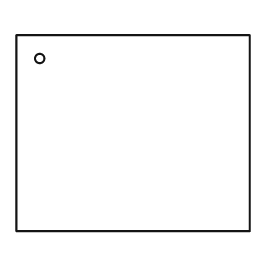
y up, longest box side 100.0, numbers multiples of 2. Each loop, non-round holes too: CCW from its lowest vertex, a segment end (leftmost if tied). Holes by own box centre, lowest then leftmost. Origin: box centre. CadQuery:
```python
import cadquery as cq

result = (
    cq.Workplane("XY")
    .moveTo(-50.0, -42.0)
    .lineTo(50.0, -42.0)
    .lineTo(50.0, 42.0)
    .lineTo(-50.0, 42.0)
    .close()
    .moveTo(-40.0, 32.0)
    .circle(2.0)
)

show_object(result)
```